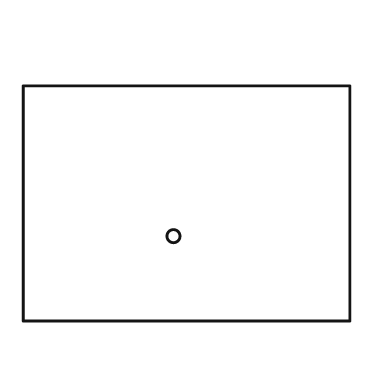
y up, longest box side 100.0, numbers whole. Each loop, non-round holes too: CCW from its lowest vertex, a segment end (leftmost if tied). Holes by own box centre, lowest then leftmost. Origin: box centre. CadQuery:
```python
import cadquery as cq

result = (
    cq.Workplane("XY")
    .moveTo(-50.0, -36.0)
    .lineTo(50.0, -36.0)
    .lineTo(50.0, 36.0)
    .lineTo(-50.0, 36.0)
    .close()
    .moveTo(-4.0, -10.0)
    .circle(2.0)
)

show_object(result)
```